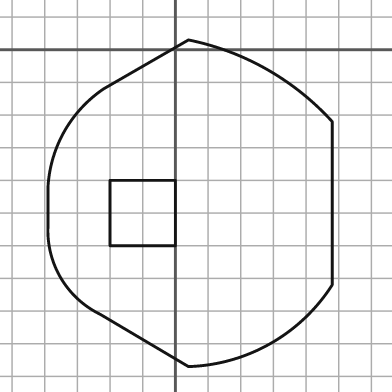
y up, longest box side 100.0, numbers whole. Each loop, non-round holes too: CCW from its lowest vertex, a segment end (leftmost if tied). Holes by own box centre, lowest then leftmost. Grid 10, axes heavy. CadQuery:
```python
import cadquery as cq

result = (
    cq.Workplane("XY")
    .moveTo(4.0, -97.0)
    .threePointArc((29.0, -90.0), (48.0, -72.0))
    .lineTo(48.0, -22.0)
    .threePointArc((28.0, -6.0), (4.0, 3.0))
    .lineTo(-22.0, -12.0)
    .threePointArc((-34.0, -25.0), (-39.0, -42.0))
    .lineTo(-39.0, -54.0)
    .threePointArc((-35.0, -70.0), (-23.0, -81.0))
    .close()
    .moveTo(-20.0, -60.0)
    .lineTo(0.0, -60.0)
    .lineTo(0.0, -40.0)
    .lineTo(-20.0, -40.0)
    .close()
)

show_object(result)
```